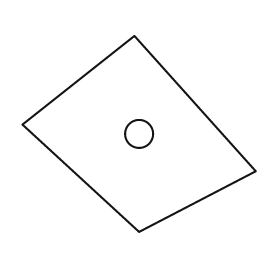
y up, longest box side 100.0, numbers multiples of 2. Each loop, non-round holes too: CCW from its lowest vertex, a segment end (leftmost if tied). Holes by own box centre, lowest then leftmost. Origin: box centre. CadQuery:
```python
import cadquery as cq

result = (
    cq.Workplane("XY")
    .moveTo(0.0, -42.0)
    .lineTo(50.0, -16.0)
    .lineTo(-2.0, 42.0)
    .lineTo(-50.0, 4.0)
    .close()
    .moveTo(0.0, 0.0)
    .circle(6.0)
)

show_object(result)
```